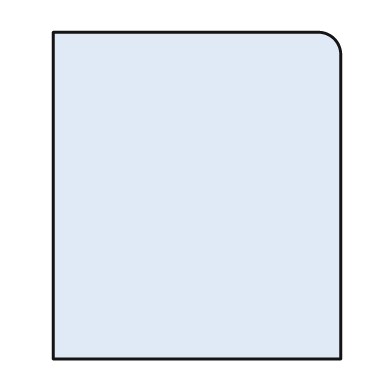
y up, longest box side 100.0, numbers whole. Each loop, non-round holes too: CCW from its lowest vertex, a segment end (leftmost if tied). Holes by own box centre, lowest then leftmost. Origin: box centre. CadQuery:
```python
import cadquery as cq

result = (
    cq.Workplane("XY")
    .moveTo(-44.0, -50.0)
    .lineTo(44.0, -50.0)
    .lineTo(44.0, 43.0)
    .threePointArc((42.0, 48.0), (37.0, 50.0))
    .lineTo(-44.0, 50.0)
    .close()
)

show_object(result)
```